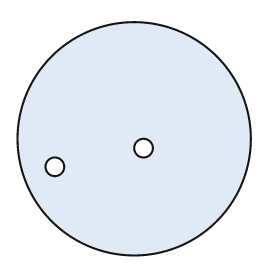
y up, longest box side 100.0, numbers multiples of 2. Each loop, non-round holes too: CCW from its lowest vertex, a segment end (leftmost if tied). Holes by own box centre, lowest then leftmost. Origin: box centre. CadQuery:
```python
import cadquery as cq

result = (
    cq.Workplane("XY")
    .moveTo(0.0, 0.0)
    .circle(50.0)
    .moveTo(-34.0, -12.0)
    .circle(4.0)
    .moveTo(4.0, -4.0)
    .circle(4.0)
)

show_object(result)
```